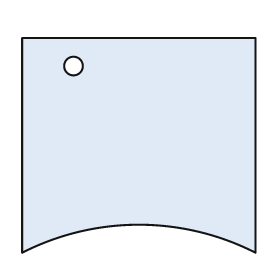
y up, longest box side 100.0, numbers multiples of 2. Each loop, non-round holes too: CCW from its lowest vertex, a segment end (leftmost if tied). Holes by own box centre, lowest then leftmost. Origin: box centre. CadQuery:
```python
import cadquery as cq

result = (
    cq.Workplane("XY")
    .moveTo(-50.0, -46.0)
    .threePointArc((0.0, -34.0), (50.0, -46.0))
    .lineTo(50.0, 46.0)
    .lineTo(-50.0, 46.0)
    .close()
    .moveTo(-28.0, 34.0)
    .circle(4.0)
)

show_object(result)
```